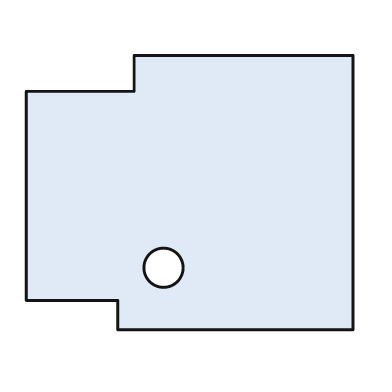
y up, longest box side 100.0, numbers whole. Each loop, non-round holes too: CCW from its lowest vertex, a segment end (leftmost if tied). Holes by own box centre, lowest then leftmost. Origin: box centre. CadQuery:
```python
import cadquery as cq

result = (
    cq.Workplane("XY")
    .moveTo(-22.0, -42.0)
    .lineTo(50.0, -42.0)
    .lineTo(50.0, 42.0)
    .lineTo(-17.0, 42.0)
    .lineTo(-17.0, 31.0)
    .lineTo(-50.0, 31.0)
    .lineTo(-50.0, -33.0)
    .lineTo(-22.0, -33.0)
    .close()
    .moveTo(-8.0, -23.0)
    .circle(6.0)
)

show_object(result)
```